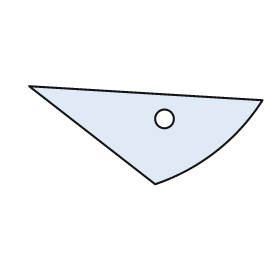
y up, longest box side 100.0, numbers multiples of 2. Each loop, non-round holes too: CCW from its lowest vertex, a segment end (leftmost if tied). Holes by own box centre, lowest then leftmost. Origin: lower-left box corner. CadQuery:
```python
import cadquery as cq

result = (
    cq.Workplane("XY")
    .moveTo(54.0, 0.0)
    .threePointArc((80.0, 14.0), (100.0, 36.0))
    .lineTo(0.0, 42.0)
    .close()
    .moveTo(58.0, 28.0)
    .circle(4.0)
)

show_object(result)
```